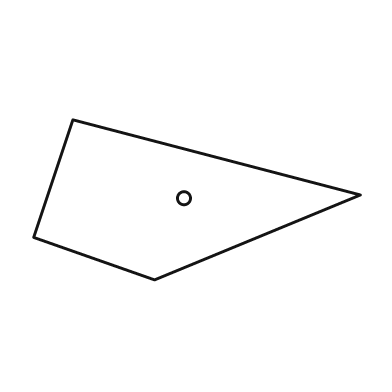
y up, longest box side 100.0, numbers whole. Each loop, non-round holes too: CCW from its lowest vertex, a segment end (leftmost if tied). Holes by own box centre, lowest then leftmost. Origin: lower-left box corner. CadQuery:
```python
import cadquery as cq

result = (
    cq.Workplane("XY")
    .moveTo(37.0, 0.0)
    .lineTo(100.0, 26.0)
    .lineTo(12.0, 49.0)
    .lineTo(0.0, 13.0)
    .close()
    .moveTo(46.0, 25.0)
    .circle(2.0)
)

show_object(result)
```